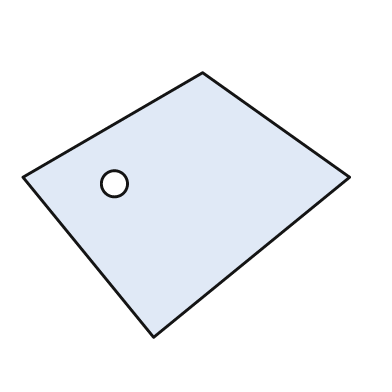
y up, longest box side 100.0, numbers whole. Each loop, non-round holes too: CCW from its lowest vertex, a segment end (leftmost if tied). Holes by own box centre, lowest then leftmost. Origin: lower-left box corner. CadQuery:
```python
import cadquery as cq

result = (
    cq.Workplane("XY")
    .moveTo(40.0, 0.0)
    .lineTo(100.0, 49.0)
    .lineTo(55.0, 81.0)
    .lineTo(0.0, 49.0)
    .close()
    .moveTo(28.0, 47.0)
    .circle(4.0)
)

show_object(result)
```